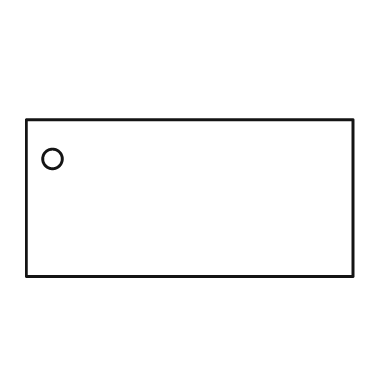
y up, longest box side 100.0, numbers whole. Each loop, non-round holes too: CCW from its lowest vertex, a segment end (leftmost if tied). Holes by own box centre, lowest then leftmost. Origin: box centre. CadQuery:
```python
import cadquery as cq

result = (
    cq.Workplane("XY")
    .moveTo(-50.0, -24.0)
    .lineTo(50.0, -24.0)
    .lineTo(50.0, 24.0)
    .lineTo(-50.0, 24.0)
    .close()
    .moveTo(-42.0, 12.0)
    .circle(3.0)
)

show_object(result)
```